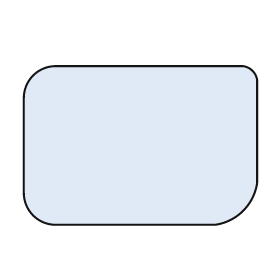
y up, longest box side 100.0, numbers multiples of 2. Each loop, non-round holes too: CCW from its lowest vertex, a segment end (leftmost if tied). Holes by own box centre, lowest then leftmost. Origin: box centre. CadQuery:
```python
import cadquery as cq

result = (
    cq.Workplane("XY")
    .moveTo(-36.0, -34.0)
    .lineTo(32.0, -34.0)
    .threePointArc((44.0, -28.0), (50.0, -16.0))
    .lineTo(50.0, 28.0)
    .threePointArc((48.0, 32.0), (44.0, 34.0))
    .lineTo(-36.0, 34.0)
    .threePointArc((-46.0, 30.0), (-50.0, 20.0))
    .lineTo(-50.0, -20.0)
    .threePointArc((-46.0, -30.0), (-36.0, -34.0))
    .close()
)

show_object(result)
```